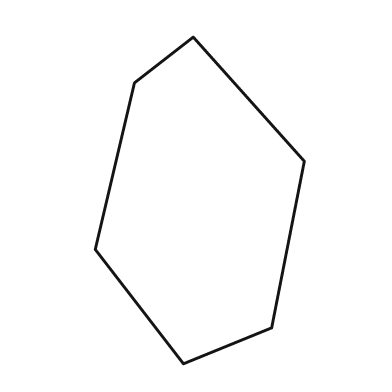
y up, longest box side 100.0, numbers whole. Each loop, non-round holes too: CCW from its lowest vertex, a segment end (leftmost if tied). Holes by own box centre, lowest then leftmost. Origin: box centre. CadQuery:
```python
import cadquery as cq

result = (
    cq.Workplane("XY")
    .moveTo(-5.0, -50.0)
    .lineTo(22.0, -39.0)
    .lineTo(32.0, 12.0)
    .lineTo(-2.0, 50.0)
    .lineTo(-20.0, 36.0)
    .lineTo(-32.0, -15.0)
    .close()
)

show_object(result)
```